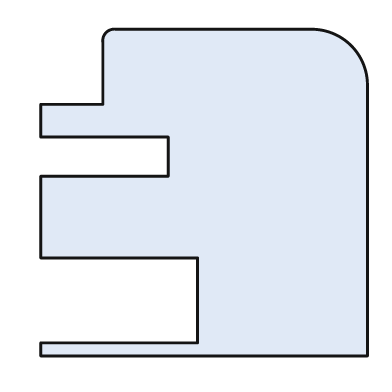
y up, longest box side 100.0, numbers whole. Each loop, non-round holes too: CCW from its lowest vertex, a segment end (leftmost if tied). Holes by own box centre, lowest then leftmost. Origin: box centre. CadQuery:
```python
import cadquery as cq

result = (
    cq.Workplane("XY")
    .moveTo(-50.0, -50.0)
    .lineTo(50.0, -50.0)
    .lineTo(50.0, 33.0)
    .threePointArc((45.0, 45.0), (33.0, 50.0))
    .lineTo(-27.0, 50.0)
    .threePointArc((-30.0, 49.0), (-31.0, 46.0))
    .lineTo(-31.0, 27.0)
    .lineTo(-50.0, 27.0)
    .lineTo(-50.0, 17.0)
    .lineTo(-11.0, 17.0)
    .lineTo(-11.0, 5.0)
    .lineTo(-50.0, 5.0)
    .lineTo(-50.0, -20.0)
    .lineTo(-2.0, -20.0)
    .lineTo(-2.0, -46.0)
    .lineTo(-50.0, -46.0)
    .close()
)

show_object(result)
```